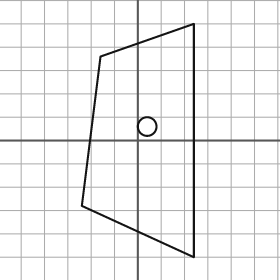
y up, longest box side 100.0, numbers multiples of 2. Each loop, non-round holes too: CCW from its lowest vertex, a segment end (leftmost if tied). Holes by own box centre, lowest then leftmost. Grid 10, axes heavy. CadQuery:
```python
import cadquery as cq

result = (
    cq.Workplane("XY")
    .moveTo(24.0, -50.0)
    .lineTo(24.0, 50.0)
    .lineTo(-16.0, 36.0)
    .lineTo(-24.0, -28.0)
    .close()
    .moveTo(4.0, 6.0)
    .circle(4.0)
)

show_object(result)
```